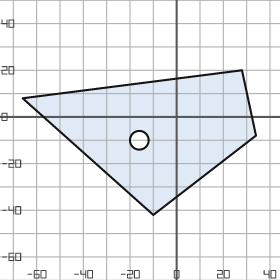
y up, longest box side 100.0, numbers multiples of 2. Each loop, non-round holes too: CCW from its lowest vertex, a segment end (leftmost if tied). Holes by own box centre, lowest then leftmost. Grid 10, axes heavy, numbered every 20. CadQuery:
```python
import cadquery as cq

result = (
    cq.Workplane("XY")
    .moveTo(-10.0, -42.0)
    .lineTo(34.0, -8.0)
    .lineTo(28.0, 20.0)
    .lineTo(-66.0, 8.0)
    .close()
    .moveTo(-16.0, -10.0)
    .circle(4.0)
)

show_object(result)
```